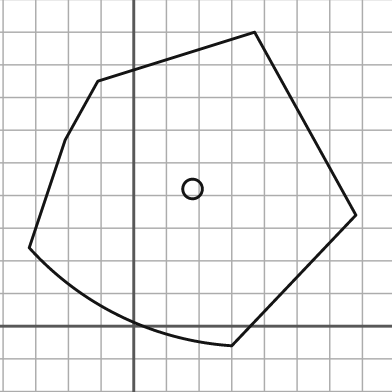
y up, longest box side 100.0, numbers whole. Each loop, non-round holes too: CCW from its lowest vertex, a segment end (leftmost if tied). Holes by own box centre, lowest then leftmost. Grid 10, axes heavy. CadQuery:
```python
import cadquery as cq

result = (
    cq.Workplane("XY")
    .moveTo(30.0, -6.0)
    .lineTo(68.0, 34.0)
    .lineTo(37.0, 90.0)
    .lineTo(-11.0, 75.0)
    .lineTo(-21.0, 57.0)
    .lineTo(-32.0, 24.0)
    .threePointArc((-4.0, 3.0), (30.0, -6.0))
    .close()
    .moveTo(18.0, 42.0)
    .circle(3.0)
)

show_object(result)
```